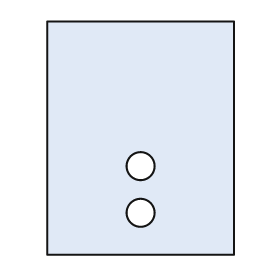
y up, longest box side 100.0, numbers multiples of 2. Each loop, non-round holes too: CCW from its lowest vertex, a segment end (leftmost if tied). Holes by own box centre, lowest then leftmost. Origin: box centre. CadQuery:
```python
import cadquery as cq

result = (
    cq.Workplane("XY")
    .moveTo(-40.0, -50.0)
    .lineTo(40.0, -50.0)
    .lineTo(40.0, 50.0)
    .lineTo(-40.0, 50.0)
    .close()
    .moveTo(0.0, -32.0)
    .circle(6.0)
    .moveTo(0.0, -12.0)
    .circle(6.0)
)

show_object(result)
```